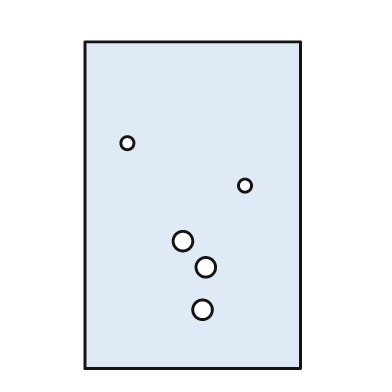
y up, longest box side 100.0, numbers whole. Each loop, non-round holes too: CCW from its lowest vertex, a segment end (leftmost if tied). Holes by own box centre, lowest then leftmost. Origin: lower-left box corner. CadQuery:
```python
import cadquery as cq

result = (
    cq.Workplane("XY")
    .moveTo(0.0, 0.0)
    .lineTo(66.0, 0.0)
    .lineTo(66.0, 100.0)
    .lineTo(0.0, 100.0)
    .close()
    .moveTo(36.0, 18.0)
    .circle(3.0)
    .moveTo(37.0, 31.0)
    .circle(3.0)
    .moveTo(30.0, 39.0)
    .circle(3.0)
    .moveTo(49.0, 56.0)
    .circle(2.0)
    .moveTo(13.0, 69.0)
    .circle(2.0)
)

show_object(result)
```